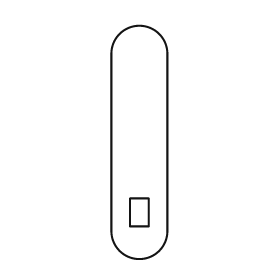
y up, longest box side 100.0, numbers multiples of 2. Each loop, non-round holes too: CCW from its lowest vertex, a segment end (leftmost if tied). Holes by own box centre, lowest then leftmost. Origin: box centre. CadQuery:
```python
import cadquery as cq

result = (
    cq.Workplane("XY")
    .moveTo(-12.0, -38.0)
    .threePointArc((0.0, -50.0), (12.0, -38.0))
    .lineTo(12.0, 38.0)
    .threePointArc((0.0, 50.0), (-12.0, 38.0))
    .close()
    .moveTo(-4.0, -36.0)
    .lineTo(4.0, -36.0)
    .lineTo(4.0, -24.0)
    .lineTo(-4.0, -24.0)
    .close()
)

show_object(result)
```